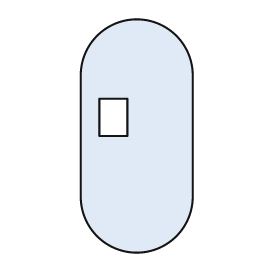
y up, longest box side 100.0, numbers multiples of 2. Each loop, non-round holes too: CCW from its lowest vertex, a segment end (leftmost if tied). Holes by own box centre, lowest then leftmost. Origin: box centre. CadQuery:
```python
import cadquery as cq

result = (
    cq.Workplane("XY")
    .moveTo(-24.0, -26.0)
    .threePointArc((0.0, -50.0), (24.0, -26.0))
    .lineTo(24.0, 26.0)
    .threePointArc((0.0, 50.0), (-24.0, 26.0))
    .close()
    .moveTo(-16.0, 0.0)
    .lineTo(-4.0, 0.0)
    .lineTo(-4.0, 16.0)
    .lineTo(-16.0, 16.0)
    .close()
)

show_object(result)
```